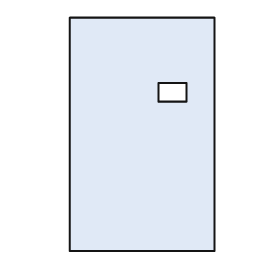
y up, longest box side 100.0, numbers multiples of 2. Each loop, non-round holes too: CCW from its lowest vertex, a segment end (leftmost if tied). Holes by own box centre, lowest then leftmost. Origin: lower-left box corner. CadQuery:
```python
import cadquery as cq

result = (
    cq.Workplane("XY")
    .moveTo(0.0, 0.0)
    .lineTo(62.0, 0.0)
    .lineTo(62.0, 100.0)
    .lineTo(0.0, 100.0)
    .close()
    .moveTo(38.0, 64.0)
    .lineTo(50.0, 64.0)
    .lineTo(50.0, 72.0)
    .lineTo(38.0, 72.0)
    .close()
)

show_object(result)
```